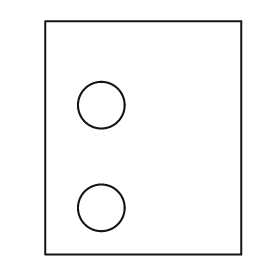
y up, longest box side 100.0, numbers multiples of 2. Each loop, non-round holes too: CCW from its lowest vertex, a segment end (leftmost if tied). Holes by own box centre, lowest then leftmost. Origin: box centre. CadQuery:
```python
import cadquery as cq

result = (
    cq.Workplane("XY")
    .moveTo(-42.0, -50.0)
    .lineTo(42.0, -50.0)
    .lineTo(42.0, 50.0)
    .lineTo(-42.0, 50.0)
    .close()
    .moveTo(-18.0, -30.0)
    .circle(10.0)
    .moveTo(-18.0, 14.0)
    .circle(10.0)
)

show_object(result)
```